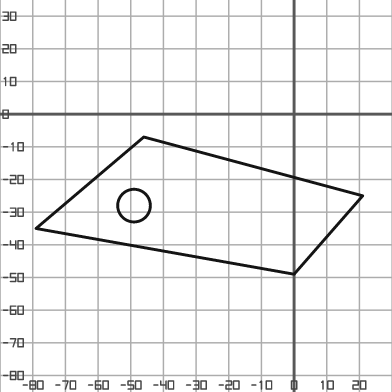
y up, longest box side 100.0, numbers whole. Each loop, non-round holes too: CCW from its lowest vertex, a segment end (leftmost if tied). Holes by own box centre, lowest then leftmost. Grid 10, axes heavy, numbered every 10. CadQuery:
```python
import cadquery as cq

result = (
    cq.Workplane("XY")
    .moveTo(0.0, -49.0)
    .lineTo(21.0, -25.0)
    .lineTo(-46.0, -7.0)
    .lineTo(-79.0, -35.0)
    .close()
    .moveTo(-49.0, -28.0)
    .circle(5.0)
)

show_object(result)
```